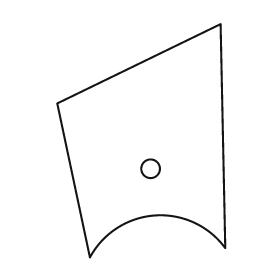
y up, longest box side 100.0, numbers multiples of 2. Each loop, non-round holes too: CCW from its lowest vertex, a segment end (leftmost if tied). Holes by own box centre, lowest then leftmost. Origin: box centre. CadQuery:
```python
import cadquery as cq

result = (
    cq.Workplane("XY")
    .moveTo(-22.0, -50.0)
    .threePointArc((6.0, -32.0), (36.0, -46.0))
    .lineTo(34.0, 50.0)
    .lineTo(-36.0, 16.0)
    .close()
    .moveTo(4.0, -12.0)
    .circle(4.0)
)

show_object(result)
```